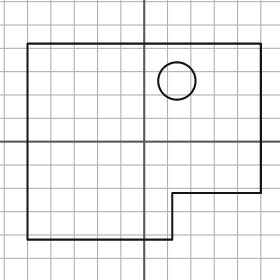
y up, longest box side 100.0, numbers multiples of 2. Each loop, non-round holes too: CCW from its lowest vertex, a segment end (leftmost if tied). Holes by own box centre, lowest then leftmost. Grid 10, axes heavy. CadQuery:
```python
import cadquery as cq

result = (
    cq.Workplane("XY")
    .moveTo(-50.0, -42.0)
    .lineTo(12.0, -42.0)
    .lineTo(12.0, -22.0)
    .lineTo(50.0, -22.0)
    .lineTo(50.0, 42.0)
    .lineTo(-50.0, 42.0)
    .close()
    .moveTo(14.0, 26.0)
    .circle(8.0)
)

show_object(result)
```